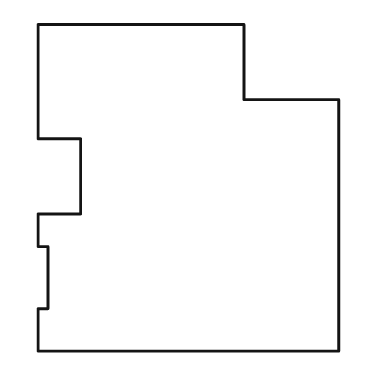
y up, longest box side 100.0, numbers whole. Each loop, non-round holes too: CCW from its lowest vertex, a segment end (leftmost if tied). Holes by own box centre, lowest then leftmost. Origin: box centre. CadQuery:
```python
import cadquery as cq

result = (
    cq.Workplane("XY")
    .moveTo(-46.0, -50.0)
    .lineTo(46.0, -50.0)
    .lineTo(46.0, 27.0)
    .lineTo(17.0, 27.0)
    .lineTo(17.0, 50.0)
    .lineTo(-46.0, 50.0)
    .lineTo(-46.0, 15.0)
    .lineTo(-33.0, 15.0)
    .lineTo(-33.0, -8.0)
    .lineTo(-46.0, -8.0)
    .lineTo(-46.0, -18.0)
    .lineTo(-43.0, -18.0)
    .lineTo(-43.0, -37.0)
    .lineTo(-46.0, -37.0)
    .close()
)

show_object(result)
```